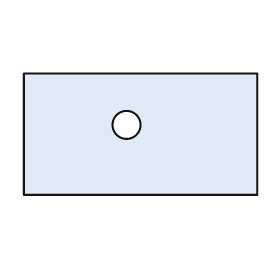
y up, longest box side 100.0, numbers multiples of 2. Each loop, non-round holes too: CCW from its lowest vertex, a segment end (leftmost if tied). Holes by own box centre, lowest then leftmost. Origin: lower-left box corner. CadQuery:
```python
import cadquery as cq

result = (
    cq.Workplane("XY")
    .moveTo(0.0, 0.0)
    .lineTo(100.0, 0.0)
    .lineTo(100.0, 52.0)
    .lineTo(0.0, 52.0)
    .close()
    .moveTo(44.0, 30.0)
    .circle(6.0)
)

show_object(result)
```